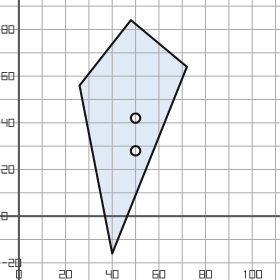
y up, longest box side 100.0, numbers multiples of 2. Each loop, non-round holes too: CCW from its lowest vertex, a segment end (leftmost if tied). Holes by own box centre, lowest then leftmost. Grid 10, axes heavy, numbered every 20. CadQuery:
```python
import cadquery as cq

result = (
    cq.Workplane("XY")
    .moveTo(40.0, -16.0)
    .lineTo(72.0, 64.0)
    .lineTo(48.0, 84.0)
    .lineTo(26.0, 56.0)
    .close()
    .moveTo(50.0, 28.0)
    .circle(2.0)
    .moveTo(50.0, 42.0)
    .circle(2.0)
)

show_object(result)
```